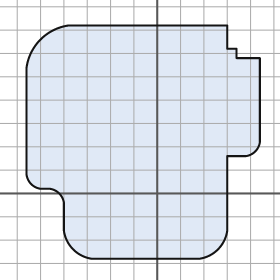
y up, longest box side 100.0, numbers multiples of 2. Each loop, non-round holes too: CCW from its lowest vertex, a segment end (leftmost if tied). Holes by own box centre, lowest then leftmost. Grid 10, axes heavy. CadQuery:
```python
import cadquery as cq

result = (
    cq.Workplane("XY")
    .moveTo(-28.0, -28.0)
    .lineTo(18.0, -28.0)
    .threePointArc((26.0, -24.0), (30.0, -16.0))
    .lineTo(30.0, 16.0)
    .lineTo(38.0, 16.0)
    .threePointArc((42.0, 18.0), (44.0, 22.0))
    .lineTo(44.0, 58.0)
    .lineTo(34.0, 58.0)
    .lineTo(34.0, 62.0)
    .lineTo(30.0, 62.0)
    .lineTo(30.0, 72.0)
    .lineTo(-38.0, 72.0)
    .threePointArc((-50.0, 66.0), (-56.0, 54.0))
    .lineTo(-56.0, 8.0)
    .threePointArc((-54.0, 4.0), (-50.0, 2.0))
    .lineTo(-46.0, 2.0)
    .threePointArc((-42.0, 0.0), (-40.0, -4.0))
    .lineTo(-40.0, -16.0)
    .threePointArc((-36.0, -24.0), (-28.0, -28.0))
    .close()
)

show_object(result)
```